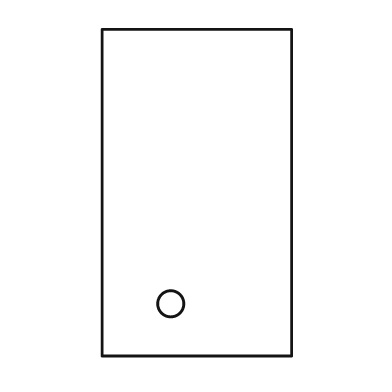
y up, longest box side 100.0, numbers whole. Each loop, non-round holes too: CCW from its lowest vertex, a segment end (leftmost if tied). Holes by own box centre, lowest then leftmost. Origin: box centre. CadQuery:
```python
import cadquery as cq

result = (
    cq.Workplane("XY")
    .moveTo(-29.0, -50.0)
    .lineTo(29.0, -50.0)
    .lineTo(29.0, 50.0)
    .lineTo(-29.0, 50.0)
    .close()
    .moveTo(-8.0, -34.0)
    .circle(4.0)
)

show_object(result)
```